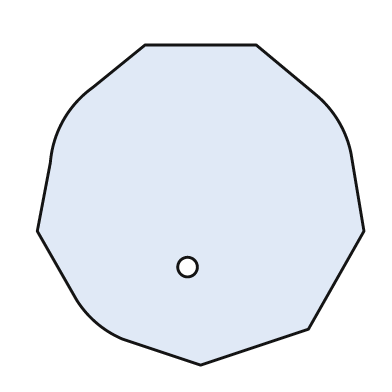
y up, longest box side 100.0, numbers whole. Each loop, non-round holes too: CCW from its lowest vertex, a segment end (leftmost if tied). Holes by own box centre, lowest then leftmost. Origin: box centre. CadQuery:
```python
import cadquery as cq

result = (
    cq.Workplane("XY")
    .moveTo(0.0, -49.0)
    .lineTo(33.0, -38.0)
    .lineTo(50.0, -8.0)
    .lineTo(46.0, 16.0)
    .threePointArc((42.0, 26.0), (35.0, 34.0))
    .lineTo(17.0, 49.0)
    .lineTo(-17.0, 49.0)
    .lineTo(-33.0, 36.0)
    .threePointArc((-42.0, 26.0), (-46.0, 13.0))
    .lineTo(-50.0, -8.0)
    .lineTo(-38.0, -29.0)
    .threePointArc((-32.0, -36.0), (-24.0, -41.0))
    .close()
    .moveTo(-4.0, -19.0)
    .circle(3.0)
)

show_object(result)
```